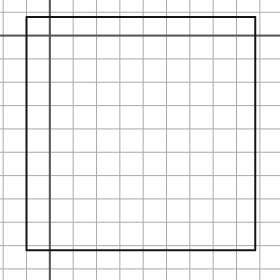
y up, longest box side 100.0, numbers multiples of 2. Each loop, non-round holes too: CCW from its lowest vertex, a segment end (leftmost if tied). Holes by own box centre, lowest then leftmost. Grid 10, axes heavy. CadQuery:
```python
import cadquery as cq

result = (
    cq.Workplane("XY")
    .moveTo(-10.0, -92.0)
    .lineTo(88.0, -92.0)
    .lineTo(88.0, 8.0)
    .lineTo(-10.0, 8.0)
    .close()
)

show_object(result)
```